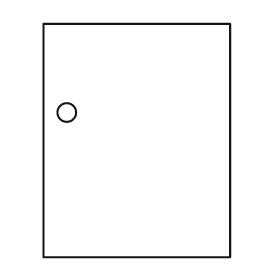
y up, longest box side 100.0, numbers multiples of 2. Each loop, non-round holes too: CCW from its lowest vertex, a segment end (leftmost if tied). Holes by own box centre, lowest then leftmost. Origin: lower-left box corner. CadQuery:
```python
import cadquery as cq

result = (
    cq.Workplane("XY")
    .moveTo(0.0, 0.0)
    .lineTo(80.0, 0.0)
    .lineTo(80.0, 100.0)
    .lineTo(0.0, 100.0)
    .close()
    .moveTo(10.0, 62.0)
    .circle(4.0)
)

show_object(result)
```